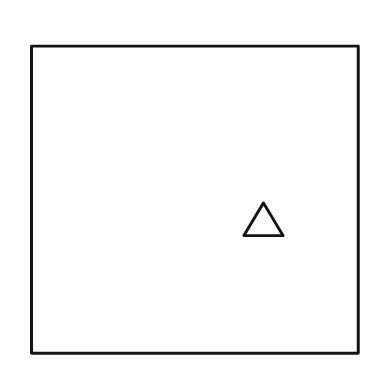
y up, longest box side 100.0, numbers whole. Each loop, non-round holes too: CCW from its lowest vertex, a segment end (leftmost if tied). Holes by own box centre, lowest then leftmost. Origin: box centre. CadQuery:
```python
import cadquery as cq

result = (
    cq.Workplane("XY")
    .moveTo(-50.0, -47.0)
    .lineTo(50.0, -47.0)
    .lineTo(50.0, 47.0)
    .lineTo(-50.0, 47.0)
    .close()
    .moveTo(15.0, -11.0)
    .lineTo(27.0, -11.0)
    .lineTo(21.0, -1.0)
    .close()
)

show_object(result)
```